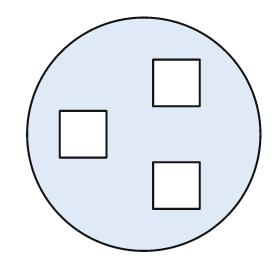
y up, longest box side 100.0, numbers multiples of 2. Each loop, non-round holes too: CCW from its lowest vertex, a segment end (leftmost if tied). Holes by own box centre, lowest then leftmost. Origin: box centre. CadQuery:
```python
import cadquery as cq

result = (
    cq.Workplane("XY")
    .moveTo(0.0, 0.0)
    .circle(50.0)
    .moveTo(4.0, -32.0)
    .lineTo(24.0, -32.0)
    .lineTo(24.0, -12.0)
    .lineTo(4.0, -12.0)
    .close()
    .moveTo(-36.0, -10.0)
    .lineTo(-16.0, -10.0)
    .lineTo(-16.0, 10.0)
    .lineTo(-36.0, 10.0)
    .close()
    .moveTo(4.0, 12.0)
    .lineTo(24.0, 12.0)
    .lineTo(24.0, 32.0)
    .lineTo(4.0, 32.0)
    .close()
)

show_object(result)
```